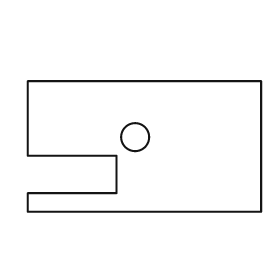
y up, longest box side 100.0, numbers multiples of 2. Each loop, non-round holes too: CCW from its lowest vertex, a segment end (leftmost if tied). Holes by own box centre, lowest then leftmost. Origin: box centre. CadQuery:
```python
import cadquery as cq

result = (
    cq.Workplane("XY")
    .moveTo(-50.0, -28.0)
    .lineTo(50.0, -28.0)
    .lineTo(50.0, 28.0)
    .lineTo(-50.0, 28.0)
    .lineTo(-50.0, -4.0)
    .lineTo(-12.0, -4.0)
    .lineTo(-12.0, -20.0)
    .lineTo(-50.0, -20.0)
    .close()
    .moveTo(-4.0, 4.0)
    .circle(6.0)
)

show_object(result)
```